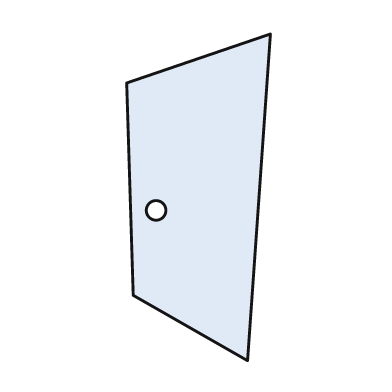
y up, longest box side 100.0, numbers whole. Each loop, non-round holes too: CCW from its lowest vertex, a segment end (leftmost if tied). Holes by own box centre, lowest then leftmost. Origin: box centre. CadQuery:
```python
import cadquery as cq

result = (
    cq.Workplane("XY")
    .moveTo(15.0, -50.0)
    .lineTo(22.0, 50.0)
    .lineTo(-22.0, 35.0)
    .lineTo(-20.0, -30.0)
    .close()
    .moveTo(-13.0, -4.0)
    .circle(3.0)
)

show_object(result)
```